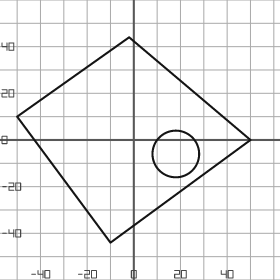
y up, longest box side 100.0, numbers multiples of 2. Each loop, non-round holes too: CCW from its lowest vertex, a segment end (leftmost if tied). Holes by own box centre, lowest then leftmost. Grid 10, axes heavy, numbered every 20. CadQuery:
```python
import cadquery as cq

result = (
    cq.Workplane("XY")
    .moveTo(-10.0, -44.0)
    .lineTo(50.0, 0.0)
    .lineTo(-2.0, 44.0)
    .lineTo(-50.0, 10.0)
    .close()
    .moveTo(18.0, -6.0)
    .circle(10.0)
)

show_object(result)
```